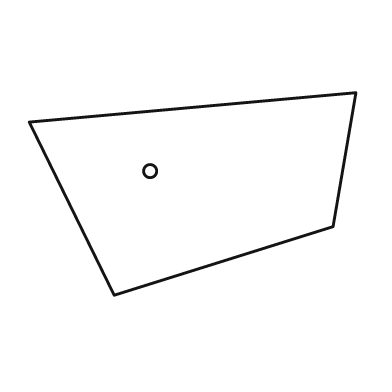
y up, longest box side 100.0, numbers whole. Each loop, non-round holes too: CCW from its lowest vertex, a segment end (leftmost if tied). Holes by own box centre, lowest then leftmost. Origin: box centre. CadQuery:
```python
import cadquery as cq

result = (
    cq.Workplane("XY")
    .moveTo(-24.0, -31.0)
    .lineTo(43.0, -10.0)
    .lineTo(50.0, 31.0)
    .lineTo(-50.0, 22.0)
    .close()
    .moveTo(-13.0, 7.0)
    .circle(2.0)
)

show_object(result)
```